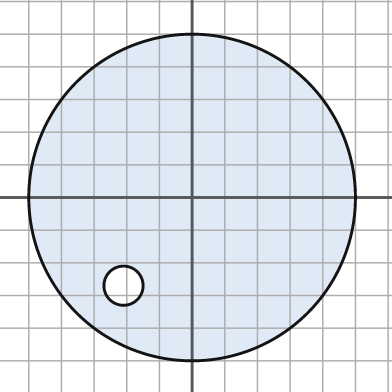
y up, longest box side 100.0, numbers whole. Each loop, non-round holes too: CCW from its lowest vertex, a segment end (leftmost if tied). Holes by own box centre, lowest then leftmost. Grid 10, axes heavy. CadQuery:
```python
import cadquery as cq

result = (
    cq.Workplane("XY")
    .moveTo(0.0, 0.0)
    .circle(50.0)
    .moveTo(-21.0, -27.0)
    .circle(6.0)
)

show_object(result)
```